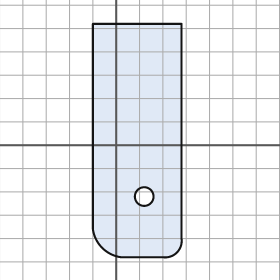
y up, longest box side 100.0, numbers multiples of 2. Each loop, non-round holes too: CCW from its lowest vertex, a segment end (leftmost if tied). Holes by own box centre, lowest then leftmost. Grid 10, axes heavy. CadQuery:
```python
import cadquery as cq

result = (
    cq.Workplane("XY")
    .moveTo(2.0, -48.0)
    .lineTo(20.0, -48.0)
    .threePointArc((26.0, -46.0), (28.0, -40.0))
    .lineTo(28.0, 52.0)
    .lineTo(-10.0, 52.0)
    .lineTo(-10.0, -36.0)
    .threePointArc((-6.0, -44.0), (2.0, -48.0))
    .close()
    .moveTo(12.0, -22.0)
    .circle(4.0)
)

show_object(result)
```